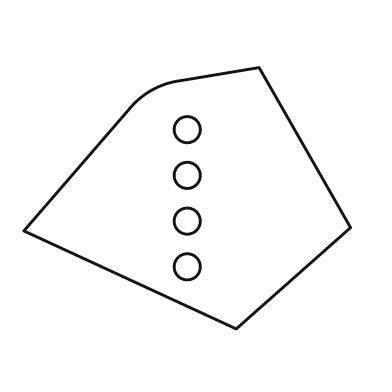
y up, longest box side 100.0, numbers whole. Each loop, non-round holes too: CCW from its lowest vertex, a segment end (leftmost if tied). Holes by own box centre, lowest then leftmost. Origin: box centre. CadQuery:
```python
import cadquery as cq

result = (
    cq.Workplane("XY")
    .moveTo(15.0, -40.0)
    .lineTo(50.0, -9.0)
    .lineTo(22.0, 40.0)
    .lineTo(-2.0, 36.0)
    .threePointArc((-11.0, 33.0), (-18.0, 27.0))
    .lineTo(-50.0, -10.0)
    .close()
    .moveTo(0.0, -21.0)
    .circle(4.0)
    .moveTo(0.0, -7.0)
    .circle(4.0)
    .moveTo(0.0, 7.0)
    .circle(4.0)
    .moveTo(0.0, 21.0)
    .circle(4.0)
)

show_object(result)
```